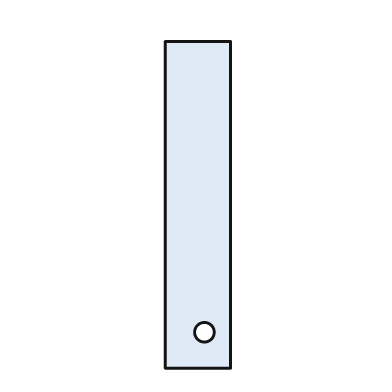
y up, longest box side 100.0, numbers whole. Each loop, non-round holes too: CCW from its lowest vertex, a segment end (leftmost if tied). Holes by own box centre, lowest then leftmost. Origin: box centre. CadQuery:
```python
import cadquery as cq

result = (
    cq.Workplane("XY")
    .moveTo(-10.0, -50.0)
    .lineTo(10.0, -50.0)
    .lineTo(10.0, 50.0)
    .lineTo(-10.0, 50.0)
    .close()
    .moveTo(2.0, -39.0)
    .circle(3.0)
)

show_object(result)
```